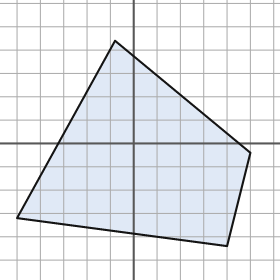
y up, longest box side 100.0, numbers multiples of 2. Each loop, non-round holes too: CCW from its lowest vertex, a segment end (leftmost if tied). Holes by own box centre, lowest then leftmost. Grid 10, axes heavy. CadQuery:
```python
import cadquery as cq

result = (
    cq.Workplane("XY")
    .moveTo(40.0, -44.0)
    .lineTo(50.0, -4.0)
    .lineTo(-8.0, 44.0)
    .lineTo(-50.0, -32.0)
    .close()
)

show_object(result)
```